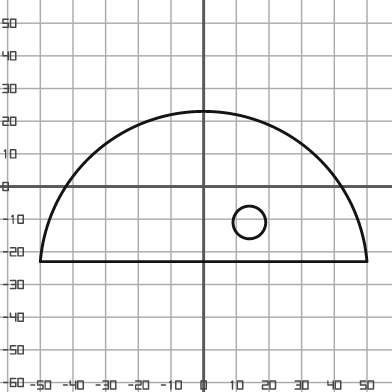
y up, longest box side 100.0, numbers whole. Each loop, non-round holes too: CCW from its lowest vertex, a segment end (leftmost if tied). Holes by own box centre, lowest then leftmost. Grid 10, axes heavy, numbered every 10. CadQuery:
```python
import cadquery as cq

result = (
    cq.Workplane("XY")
    .moveTo(-50.0, -23.0)
    .lineTo(50.0, -23.0)
    .threePointArc((0.0, 23.0), (-50.0, -23.0))
    .close()
    .moveTo(14.0, -11.0)
    .circle(5.0)
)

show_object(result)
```